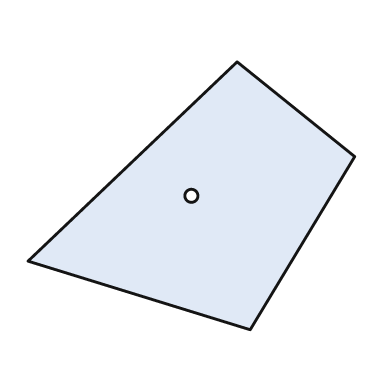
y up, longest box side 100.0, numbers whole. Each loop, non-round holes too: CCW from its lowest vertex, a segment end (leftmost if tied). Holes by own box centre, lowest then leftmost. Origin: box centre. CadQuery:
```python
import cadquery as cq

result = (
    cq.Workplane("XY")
    .moveTo(18.0, -41.0)
    .lineTo(50.0, 12.0)
    .lineTo(14.0, 41.0)
    .lineTo(-50.0, -20.0)
    .close()
    .moveTo(0.0, 0.0)
    .circle(2.0)
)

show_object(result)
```